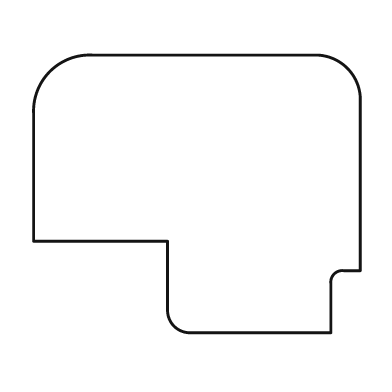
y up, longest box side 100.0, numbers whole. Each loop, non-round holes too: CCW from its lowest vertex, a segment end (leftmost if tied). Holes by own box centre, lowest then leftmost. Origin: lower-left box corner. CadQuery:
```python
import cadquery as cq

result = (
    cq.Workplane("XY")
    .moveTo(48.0, 0.0)
    .lineTo(91.0, 0.0)
    .lineTo(91.0, 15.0)
    .threePointArc((92.0, 18.0), (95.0, 19.0))
    .lineTo(100.0, 19.0)
    .lineTo(100.0, 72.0)
    .threePointArc((96.0, 81.0), (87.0, 85.0))
    .lineTo(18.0, 85.0)
    .threePointArc((5.0, 80.0), (0.0, 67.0))
    .lineTo(0.0, 28.0)
    .lineTo(41.0, 28.0)
    .lineTo(41.0, 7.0)
    .threePointArc((43.0, 2.0), (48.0, 0.0))
    .close()
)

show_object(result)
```